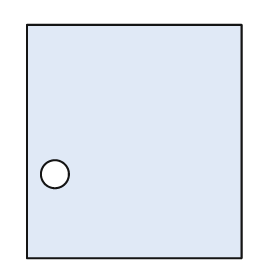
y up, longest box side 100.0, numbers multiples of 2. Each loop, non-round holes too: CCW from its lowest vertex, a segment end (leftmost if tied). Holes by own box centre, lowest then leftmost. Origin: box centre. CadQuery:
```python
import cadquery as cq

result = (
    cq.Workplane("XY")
    .moveTo(-46.0, -50.0)
    .lineTo(46.0, -50.0)
    .lineTo(46.0, 50.0)
    .lineTo(-46.0, 50.0)
    .close()
    .moveTo(-34.0, -14.0)
    .circle(6.0)
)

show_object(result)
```